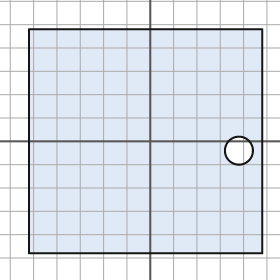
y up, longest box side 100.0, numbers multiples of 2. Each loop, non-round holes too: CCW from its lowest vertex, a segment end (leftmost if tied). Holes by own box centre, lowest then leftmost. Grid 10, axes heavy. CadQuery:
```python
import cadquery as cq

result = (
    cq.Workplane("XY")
    .moveTo(-52.0, -48.0)
    .lineTo(48.0, -48.0)
    .lineTo(48.0, 48.0)
    .lineTo(-52.0, 48.0)
    .close()
    .moveTo(38.0, -4.0)
    .circle(6.0)
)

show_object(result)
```